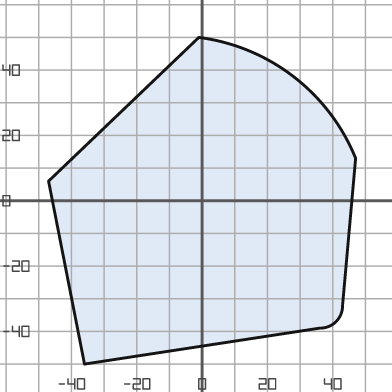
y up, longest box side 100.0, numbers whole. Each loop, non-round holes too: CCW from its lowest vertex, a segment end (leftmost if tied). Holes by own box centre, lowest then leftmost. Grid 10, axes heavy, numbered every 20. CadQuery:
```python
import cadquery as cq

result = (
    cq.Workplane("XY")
    .moveTo(-36.0, -50.0)
    .lineTo(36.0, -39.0)
    .threePointArc((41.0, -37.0), (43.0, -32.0))
    .lineTo(47.0, 13.0)
    .threePointArc((28.0, 38.0), (-1.0, 50.0))
    .lineTo(-47.0, 6.0)
    .close()
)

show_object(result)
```